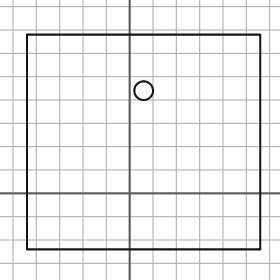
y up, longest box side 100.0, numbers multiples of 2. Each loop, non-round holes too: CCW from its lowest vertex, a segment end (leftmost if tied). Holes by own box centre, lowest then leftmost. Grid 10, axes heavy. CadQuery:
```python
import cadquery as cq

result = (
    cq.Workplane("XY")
    .moveTo(-44.0, -24.0)
    .lineTo(56.0, -24.0)
    .lineTo(56.0, 68.0)
    .lineTo(-44.0, 68.0)
    .close()
    .moveTo(6.0, 44.0)
    .circle(4.0)
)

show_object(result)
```